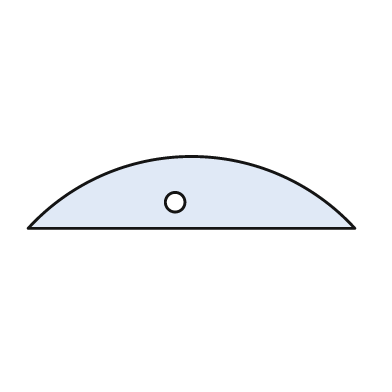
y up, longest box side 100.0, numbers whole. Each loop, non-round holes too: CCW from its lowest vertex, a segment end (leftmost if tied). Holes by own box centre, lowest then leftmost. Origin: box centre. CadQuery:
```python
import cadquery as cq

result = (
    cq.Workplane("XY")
    .moveTo(-50.0, -11.0)
    .lineTo(50.0, -11.0)
    .threePointArc((0.0, 11.0), (-50.0, -11.0))
    .close()
    .moveTo(-5.0, -3.0)
    .circle(3.0)
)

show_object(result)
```